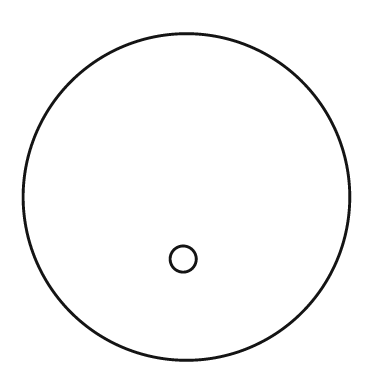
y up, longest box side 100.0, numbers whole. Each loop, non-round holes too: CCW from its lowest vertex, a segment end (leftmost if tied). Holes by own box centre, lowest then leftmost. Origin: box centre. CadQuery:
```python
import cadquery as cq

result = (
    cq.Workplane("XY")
    .moveTo(0.0, 0.0)
    .circle(50.0)
    .moveTo(-1.0, -19.0)
    .circle(4.0)
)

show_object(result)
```